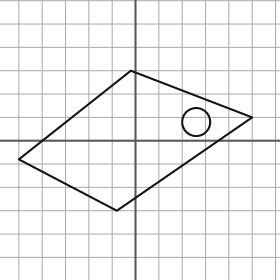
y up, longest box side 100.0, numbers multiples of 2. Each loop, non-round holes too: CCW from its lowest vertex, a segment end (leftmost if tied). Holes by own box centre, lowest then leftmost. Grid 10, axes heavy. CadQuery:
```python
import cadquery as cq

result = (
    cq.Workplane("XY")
    .moveTo(-8.0, -30.0)
    .lineTo(50.0, 10.0)
    .lineTo(-2.0, 30.0)
    .lineTo(-50.0, -8.0)
    .close()
    .moveTo(26.0, 8.0)
    .circle(6.0)
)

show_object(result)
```